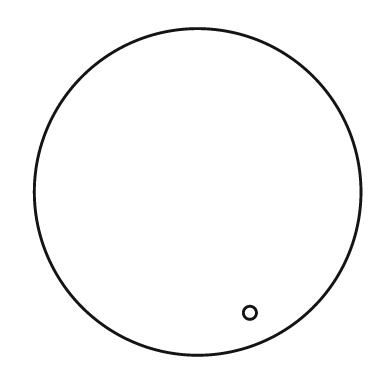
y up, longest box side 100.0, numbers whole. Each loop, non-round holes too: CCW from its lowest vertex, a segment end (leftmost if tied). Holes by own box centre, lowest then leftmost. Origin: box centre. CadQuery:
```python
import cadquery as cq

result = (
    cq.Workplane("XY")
    .moveTo(0.0, 0.0)
    .circle(50.0)
    .moveTo(16.0, -37.0)
    .circle(2.0)
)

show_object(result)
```